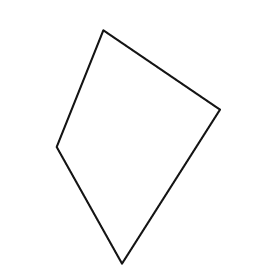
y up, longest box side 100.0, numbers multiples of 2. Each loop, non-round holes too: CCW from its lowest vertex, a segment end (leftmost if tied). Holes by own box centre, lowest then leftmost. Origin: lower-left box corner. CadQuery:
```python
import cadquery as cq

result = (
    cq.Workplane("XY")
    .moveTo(28.0, 0.0)
    .lineTo(70.0, 66.0)
    .lineTo(20.0, 100.0)
    .lineTo(0.0, 50.0)
    .close()
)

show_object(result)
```